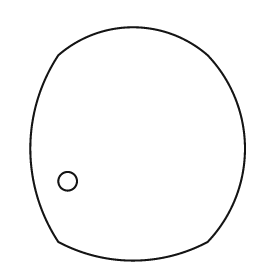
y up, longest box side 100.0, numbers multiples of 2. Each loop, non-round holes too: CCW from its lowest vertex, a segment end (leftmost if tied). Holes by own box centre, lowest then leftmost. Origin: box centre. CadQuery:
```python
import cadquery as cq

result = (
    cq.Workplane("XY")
    .moveTo(-34.0, -42.0)
    .threePointArc((-2.0, -50.0), (30.0, -42.0))
    .threePointArc((46.0, -2.0), (30.0, 38.0))
    .threePointArc((-2.0, 50.0), (-34.0, 38.0))
    .threePointArc((-46.0, -2.0), (-34.0, -42.0))
    .close()
    .moveTo(-30.0, -16.0)
    .circle(4.0)
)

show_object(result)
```